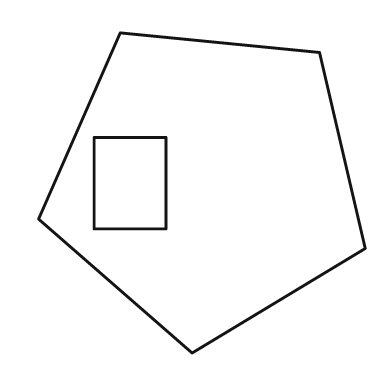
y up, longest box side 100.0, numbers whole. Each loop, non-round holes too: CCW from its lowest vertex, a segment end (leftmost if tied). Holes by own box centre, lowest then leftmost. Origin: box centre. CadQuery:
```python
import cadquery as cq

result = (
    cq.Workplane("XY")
    .moveTo(-3.0, -49.0)
    .lineTo(50.0, -17.0)
    .lineTo(36.0, 43.0)
    .lineTo(-25.0, 49.0)
    .lineTo(-50.0, -8.0)
    .close()
    .moveTo(-33.0, -11.0)
    .lineTo(-11.0, -11.0)
    .lineTo(-11.0, 17.0)
    .lineTo(-33.0, 17.0)
    .close()
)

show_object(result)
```